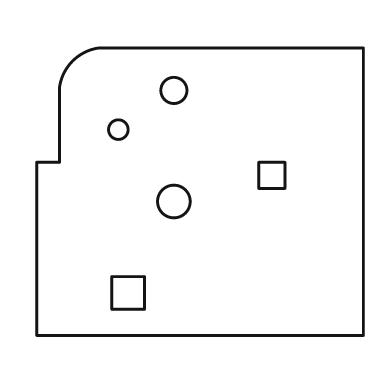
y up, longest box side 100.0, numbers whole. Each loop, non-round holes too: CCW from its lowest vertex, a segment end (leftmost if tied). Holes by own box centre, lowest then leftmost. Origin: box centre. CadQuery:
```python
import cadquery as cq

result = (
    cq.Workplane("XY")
    .moveTo(-50.0, -44.0)
    .lineTo(50.0, -44.0)
    .lineTo(50.0, 44.0)
    .lineTo(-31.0, 44.0)
    .threePointArc((-39.0, 40.0), (-43.0, 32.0))
    .lineTo(-43.0, 9.0)
    .lineTo(-50.0, 9.0)
    .close()
    .moveTo(-27.0, -36.0)
    .lineTo(-17.0, -36.0)
    .lineTo(-17.0, -26.0)
    .lineTo(-27.0, -26.0)
    .close()
    .moveTo(-8.0, -3.0)
    .circle(5.0)
    .moveTo(18.0, 1.0)
    .lineTo(26.0, 1.0)
    .lineTo(26.0, 9.0)
    .lineTo(18.0, 9.0)
    .close()
    .moveTo(-25.0, 19.0)
    .circle(3.0)
    .moveTo(-8.0, 31.0)
    .circle(4.0)
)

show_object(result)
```